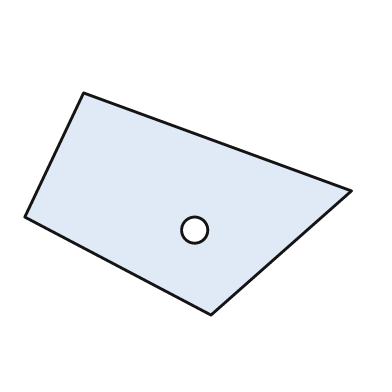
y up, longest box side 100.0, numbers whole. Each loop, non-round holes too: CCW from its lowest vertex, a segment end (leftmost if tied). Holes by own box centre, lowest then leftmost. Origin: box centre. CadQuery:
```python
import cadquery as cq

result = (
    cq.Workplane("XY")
    .moveTo(7.0, -34.0)
    .lineTo(50.0, 4.0)
    .lineTo(-32.0, 34.0)
    .lineTo(-50.0, -4.0)
    .close()
    .moveTo(2.0, -8.0)
    .circle(4.0)
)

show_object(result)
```